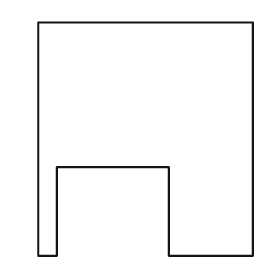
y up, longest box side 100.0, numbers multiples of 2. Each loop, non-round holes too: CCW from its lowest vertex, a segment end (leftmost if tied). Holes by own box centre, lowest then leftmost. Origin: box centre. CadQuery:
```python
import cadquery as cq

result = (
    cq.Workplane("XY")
    .moveTo(-46.0, -50.0)
    .lineTo(-38.0, -50.0)
    .lineTo(-38.0, -12.0)
    .lineTo(10.0, -12.0)
    .lineTo(10.0, -50.0)
    .lineTo(46.0, -50.0)
    .lineTo(46.0, 50.0)
    .lineTo(-46.0, 50.0)
    .close()
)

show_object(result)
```